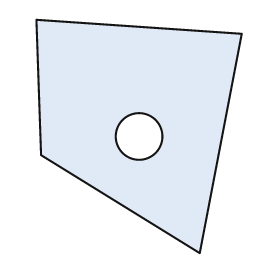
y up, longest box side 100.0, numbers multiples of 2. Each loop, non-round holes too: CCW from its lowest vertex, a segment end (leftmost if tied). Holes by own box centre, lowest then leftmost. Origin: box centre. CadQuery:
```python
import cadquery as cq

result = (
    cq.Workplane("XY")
    .moveTo(26.0, -50.0)
    .lineTo(44.0, 44.0)
    .lineTo(-44.0, 50.0)
    .lineTo(-42.0, -8.0)
    .close()
    .moveTo(0.0, 0.0)
    .circle(10.0)
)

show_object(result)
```